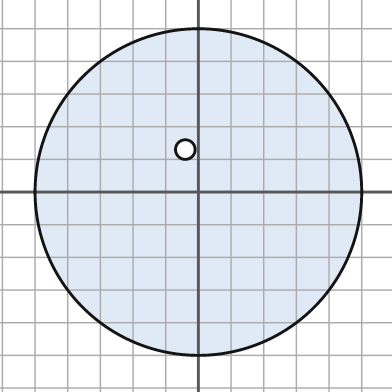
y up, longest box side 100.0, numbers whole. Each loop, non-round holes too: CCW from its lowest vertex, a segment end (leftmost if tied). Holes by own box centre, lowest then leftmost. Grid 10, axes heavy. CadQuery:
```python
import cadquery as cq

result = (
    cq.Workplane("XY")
    .moveTo(0.0, 0.0)
    .circle(50.0)
    .moveTo(-4.0, 13.0)
    .circle(3.0)
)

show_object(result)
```